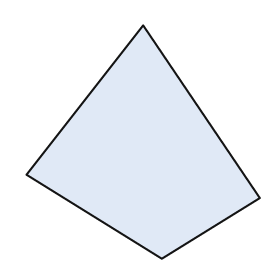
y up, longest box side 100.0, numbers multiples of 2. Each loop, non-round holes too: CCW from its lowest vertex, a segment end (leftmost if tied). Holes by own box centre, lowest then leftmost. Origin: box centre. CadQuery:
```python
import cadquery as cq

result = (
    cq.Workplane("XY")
    .moveTo(8.0, -50.0)
    .lineTo(50.0, -24.0)
    .lineTo(0.0, 50.0)
    .lineTo(-50.0, -14.0)
    .close()
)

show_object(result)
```